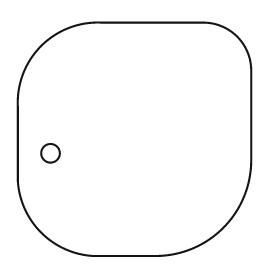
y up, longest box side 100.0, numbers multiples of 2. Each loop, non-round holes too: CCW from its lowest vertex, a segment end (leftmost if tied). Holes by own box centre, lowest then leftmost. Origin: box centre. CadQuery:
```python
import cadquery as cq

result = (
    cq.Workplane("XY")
    .moveTo(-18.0, -50.0)
    .lineTo(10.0, -50.0)
    .threePointArc((38.0, -38.0), (50.0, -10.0))
    .lineTo(50.0, 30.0)
    .threePointArc((44.0, 44.0), (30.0, 50.0))
    .lineTo(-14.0, 50.0)
    .threePointArc((-40.0, 40.0), (-50.0, 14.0))
    .lineTo(-50.0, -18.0)
    .threePointArc((-40.0, -40.0), (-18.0, -50.0))
    .close()
    .moveTo(-36.0, -6.0)
    .circle(4.0)
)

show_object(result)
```